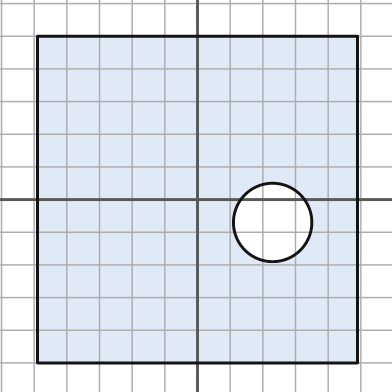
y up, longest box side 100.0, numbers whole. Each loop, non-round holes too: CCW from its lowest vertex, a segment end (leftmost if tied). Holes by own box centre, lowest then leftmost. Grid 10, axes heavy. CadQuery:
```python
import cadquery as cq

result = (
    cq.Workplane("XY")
    .moveTo(-49.0, -50.0)
    .lineTo(49.0, -50.0)
    .lineTo(49.0, 50.0)
    .lineTo(-49.0, 50.0)
    .close()
    .moveTo(23.0, -7.0)
    .circle(12.0)
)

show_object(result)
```